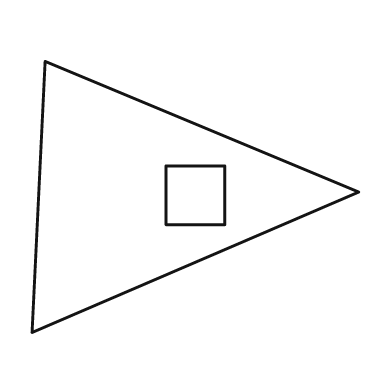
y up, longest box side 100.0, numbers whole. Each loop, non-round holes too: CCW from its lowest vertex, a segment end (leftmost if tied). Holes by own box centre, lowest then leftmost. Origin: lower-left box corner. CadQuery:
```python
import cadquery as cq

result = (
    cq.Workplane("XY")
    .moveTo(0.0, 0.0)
    .lineTo(100.0, 43.0)
    .lineTo(4.0, 83.0)
    .close()
    .moveTo(41.0, 33.0)
    .lineTo(59.0, 33.0)
    .lineTo(59.0, 51.0)
    .lineTo(41.0, 51.0)
    .close()
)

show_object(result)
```